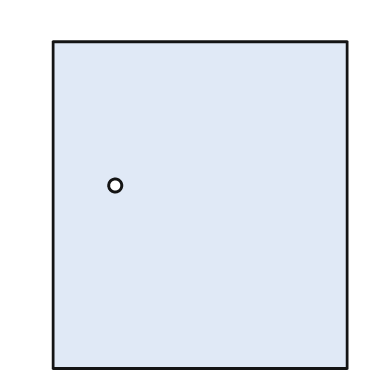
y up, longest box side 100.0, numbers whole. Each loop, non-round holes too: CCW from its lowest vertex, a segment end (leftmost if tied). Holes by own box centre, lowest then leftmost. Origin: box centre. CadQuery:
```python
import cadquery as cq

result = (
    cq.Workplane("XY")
    .moveTo(-45.0, -50.0)
    .lineTo(45.0, -50.0)
    .lineTo(45.0, 50.0)
    .lineTo(-45.0, 50.0)
    .close()
    .moveTo(-26.0, 6.0)
    .circle(2.0)
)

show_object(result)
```